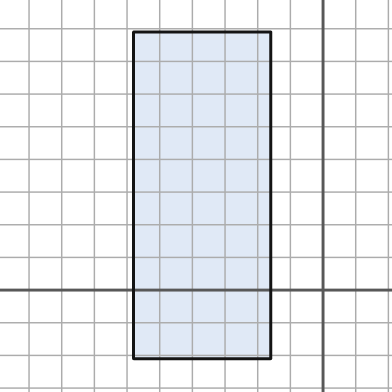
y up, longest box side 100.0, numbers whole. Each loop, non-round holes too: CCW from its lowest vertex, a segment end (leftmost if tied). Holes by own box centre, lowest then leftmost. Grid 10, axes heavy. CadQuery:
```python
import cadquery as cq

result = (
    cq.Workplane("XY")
    .moveTo(-58.0, -21.0)
    .lineTo(-16.0, -21.0)
    .lineTo(-16.0, 79.0)
    .lineTo(-58.0, 79.0)
    .close()
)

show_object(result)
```